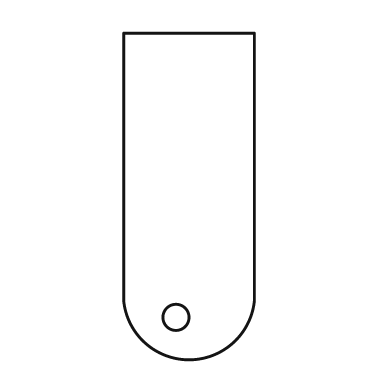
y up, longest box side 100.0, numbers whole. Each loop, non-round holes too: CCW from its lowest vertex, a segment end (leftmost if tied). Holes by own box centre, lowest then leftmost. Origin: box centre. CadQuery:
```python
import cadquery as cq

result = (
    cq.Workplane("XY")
    .moveTo(-20.0, -32.0)
    .threePointArc((0.0, -50.0), (20.0, -32.0))
    .lineTo(20.0, 50.0)
    .lineTo(-20.0, 50.0)
    .close()
    .moveTo(-4.0, -37.0)
    .circle(4.0)
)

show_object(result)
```